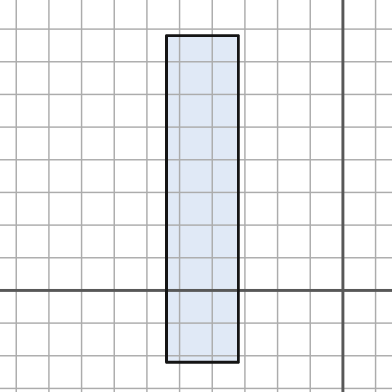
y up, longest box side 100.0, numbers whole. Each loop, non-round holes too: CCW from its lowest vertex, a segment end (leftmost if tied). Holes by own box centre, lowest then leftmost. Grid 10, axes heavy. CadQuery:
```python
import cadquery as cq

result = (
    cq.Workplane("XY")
    .moveTo(-54.0, -22.0)
    .lineTo(-32.0, -22.0)
    .lineTo(-32.0, 78.0)
    .lineTo(-54.0, 78.0)
    .close()
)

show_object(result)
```